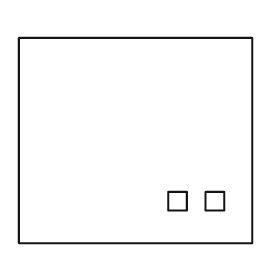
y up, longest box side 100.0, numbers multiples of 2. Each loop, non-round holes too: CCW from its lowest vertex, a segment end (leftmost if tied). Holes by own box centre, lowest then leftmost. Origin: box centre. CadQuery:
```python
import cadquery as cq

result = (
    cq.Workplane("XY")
    .moveTo(-50.0, -44.0)
    .lineTo(50.0, -44.0)
    .lineTo(50.0, 44.0)
    .lineTo(-50.0, 44.0)
    .close()
    .moveTo(14.0, -30.0)
    .lineTo(22.0, -30.0)
    .lineTo(22.0, -22.0)
    .lineTo(14.0, -22.0)
    .close()
    .moveTo(30.0, -30.0)
    .lineTo(38.0, -30.0)
    .lineTo(38.0, -22.0)
    .lineTo(30.0, -22.0)
    .close()
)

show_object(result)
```